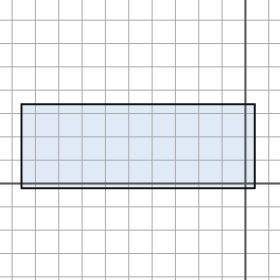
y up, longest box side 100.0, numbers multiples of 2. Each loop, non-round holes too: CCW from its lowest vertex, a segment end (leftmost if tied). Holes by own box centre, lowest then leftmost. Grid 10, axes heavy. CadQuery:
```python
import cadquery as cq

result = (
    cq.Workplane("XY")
    .moveTo(-96.0, -2.0)
    .lineTo(4.0, -2.0)
    .lineTo(4.0, 34.0)
    .lineTo(-96.0, 34.0)
    .close()
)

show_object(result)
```